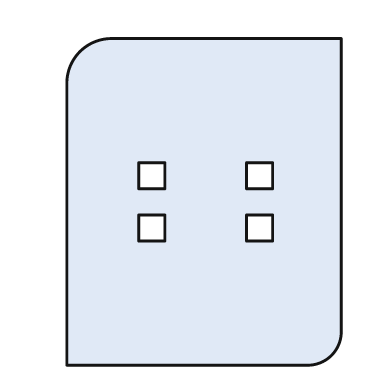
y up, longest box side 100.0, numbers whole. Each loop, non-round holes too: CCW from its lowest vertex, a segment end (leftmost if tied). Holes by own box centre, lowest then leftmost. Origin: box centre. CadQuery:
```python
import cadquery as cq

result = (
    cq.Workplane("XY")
    .moveTo(-42.0, -50.0)
    .lineTo(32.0, -50.0)
    .threePointArc((39.0, -47.0), (42.0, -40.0))
    .lineTo(42.0, 50.0)
    .lineTo(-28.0, 50.0)
    .threePointArc((-38.0, 46.0), (-42.0, 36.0))
    .close()
    .moveTo(-20.0, -12.0)
    .lineTo(-12.0, -12.0)
    .lineTo(-12.0, -4.0)
    .lineTo(-20.0, -4.0)
    .close()
    .moveTo(13.0, -12.0)
    .lineTo(21.0, -12.0)
    .lineTo(21.0, -4.0)
    .lineTo(13.0, -4.0)
    .close()
    .moveTo(-20.0, 4.0)
    .lineTo(-12.0, 4.0)
    .lineTo(-12.0, 12.0)
    .lineTo(-20.0, 12.0)
    .close()
    .moveTo(13.0, 4.0)
    .lineTo(21.0, 4.0)
    .lineTo(21.0, 12.0)
    .lineTo(13.0, 12.0)
    .close()
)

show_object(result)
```